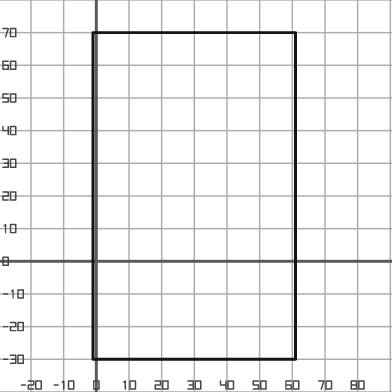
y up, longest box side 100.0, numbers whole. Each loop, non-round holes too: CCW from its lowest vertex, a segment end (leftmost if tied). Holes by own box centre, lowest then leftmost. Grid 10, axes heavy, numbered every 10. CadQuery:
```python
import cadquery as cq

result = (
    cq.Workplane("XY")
    .moveTo(-1.0, -30.0)
    .lineTo(61.0, -30.0)
    .lineTo(61.0, 70.0)
    .lineTo(-1.0, 70.0)
    .close()
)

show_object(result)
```